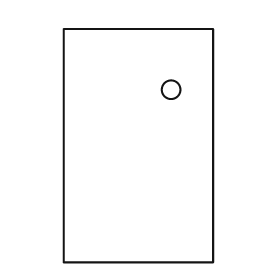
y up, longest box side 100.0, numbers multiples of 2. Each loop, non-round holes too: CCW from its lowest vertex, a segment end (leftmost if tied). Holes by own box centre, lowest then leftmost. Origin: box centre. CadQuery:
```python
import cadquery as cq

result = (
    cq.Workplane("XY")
    .moveTo(-32.0, -50.0)
    .lineTo(32.0, -50.0)
    .lineTo(32.0, 50.0)
    .lineTo(-32.0, 50.0)
    .close()
    .moveTo(14.0, 24.0)
    .circle(4.0)
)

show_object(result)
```